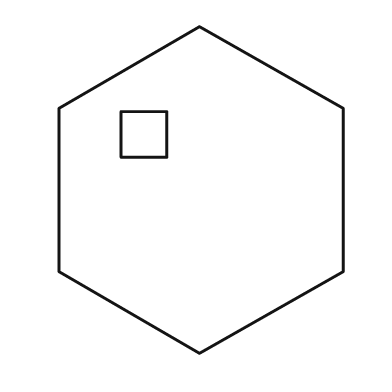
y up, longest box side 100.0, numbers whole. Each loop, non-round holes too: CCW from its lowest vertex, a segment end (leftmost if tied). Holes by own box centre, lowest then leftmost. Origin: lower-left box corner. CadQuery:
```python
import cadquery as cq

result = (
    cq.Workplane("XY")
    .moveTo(43.0, 0.0)
    .lineTo(87.0, 25.0)
    .lineTo(87.0, 75.0)
    .lineTo(43.0, 100.0)
    .lineTo(0.0, 75.0)
    .lineTo(0.0, 25.0)
    .close()
    .moveTo(19.0, 60.0)
    .lineTo(33.0, 60.0)
    .lineTo(33.0, 74.0)
    .lineTo(19.0, 74.0)
    .close()
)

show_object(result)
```